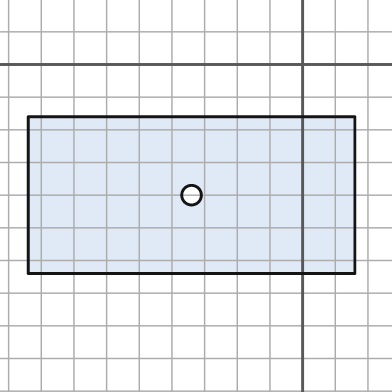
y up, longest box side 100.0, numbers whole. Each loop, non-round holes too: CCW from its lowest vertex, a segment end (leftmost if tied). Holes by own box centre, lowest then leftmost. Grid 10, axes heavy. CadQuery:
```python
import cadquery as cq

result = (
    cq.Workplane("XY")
    .moveTo(-84.0, -64.0)
    .lineTo(16.0, -64.0)
    .lineTo(16.0, -16.0)
    .lineTo(-84.0, -16.0)
    .close()
    .moveTo(-34.0, -40.0)
    .circle(3.0)
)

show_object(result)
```